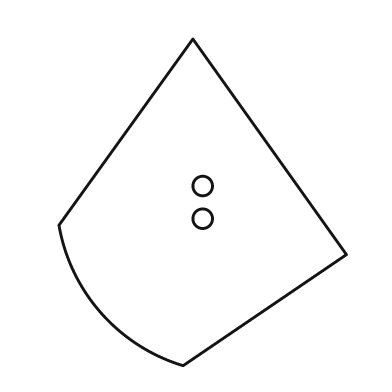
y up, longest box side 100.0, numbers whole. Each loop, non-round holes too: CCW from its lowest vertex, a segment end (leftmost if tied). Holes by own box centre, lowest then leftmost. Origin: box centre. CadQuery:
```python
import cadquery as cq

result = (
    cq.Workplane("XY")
    .moveTo(-6.0, -50.0)
    .lineTo(44.0, -16.0)
    .lineTo(-3.0, 50.0)
    .lineTo(-44.0, -7.0)
    .threePointArc((-31.0, -34.0), (-6.0, -50.0))
    .close()
    .moveTo(0.0, -5.0)
    .circle(3.0)
    .moveTo(0.0, 5.0)
    .circle(3.0)
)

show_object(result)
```